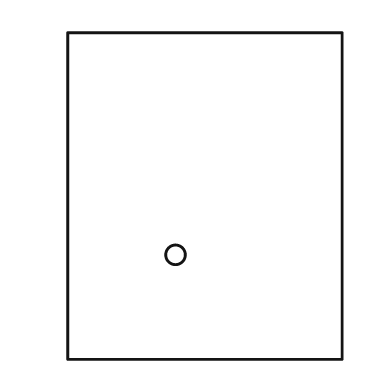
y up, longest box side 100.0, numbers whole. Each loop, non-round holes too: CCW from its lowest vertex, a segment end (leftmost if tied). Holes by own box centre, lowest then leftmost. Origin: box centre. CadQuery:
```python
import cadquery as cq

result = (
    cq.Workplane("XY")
    .moveTo(-42.0, -50.0)
    .lineTo(42.0, -50.0)
    .lineTo(42.0, 50.0)
    .lineTo(-42.0, 50.0)
    .close()
    .moveTo(-9.0, -18.0)
    .circle(3.0)
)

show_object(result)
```